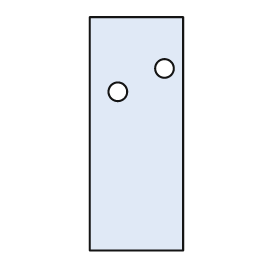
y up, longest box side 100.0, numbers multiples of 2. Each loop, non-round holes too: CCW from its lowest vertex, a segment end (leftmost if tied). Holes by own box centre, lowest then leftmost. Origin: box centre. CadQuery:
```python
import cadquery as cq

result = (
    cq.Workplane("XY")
    .moveTo(-20.0, -50.0)
    .lineTo(20.0, -50.0)
    .lineTo(20.0, 50.0)
    .lineTo(-20.0, 50.0)
    .close()
    .moveTo(-8.0, 18.0)
    .circle(4.0)
    .moveTo(12.0, 28.0)
    .circle(4.0)
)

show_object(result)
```